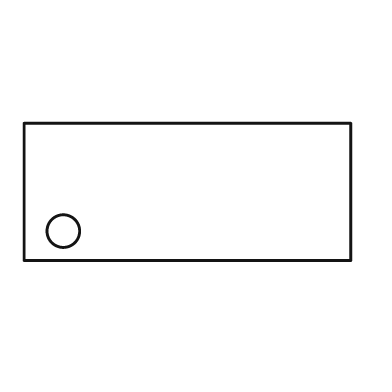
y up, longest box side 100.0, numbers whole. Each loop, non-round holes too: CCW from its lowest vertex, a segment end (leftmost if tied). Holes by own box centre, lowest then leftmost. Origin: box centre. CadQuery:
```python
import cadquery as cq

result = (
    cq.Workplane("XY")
    .moveTo(-50.0, -21.0)
    .lineTo(50.0, -21.0)
    .lineTo(50.0, 21.0)
    .lineTo(-50.0, 21.0)
    .close()
    .moveTo(-38.0, -12.0)
    .circle(5.0)
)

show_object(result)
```